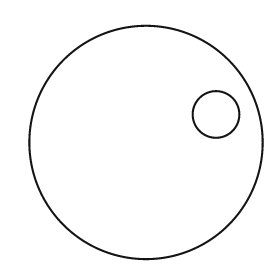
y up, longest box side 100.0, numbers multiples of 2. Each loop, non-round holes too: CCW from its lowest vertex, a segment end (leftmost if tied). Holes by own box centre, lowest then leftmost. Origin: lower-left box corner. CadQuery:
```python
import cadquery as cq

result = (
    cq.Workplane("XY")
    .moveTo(50.0, 50.0)
    .circle(50.0)
    .moveTo(80.0, 62.0)
    .circle(10.0)
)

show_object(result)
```